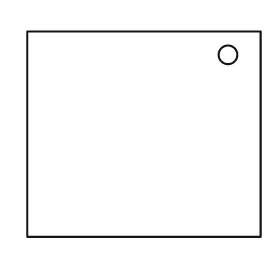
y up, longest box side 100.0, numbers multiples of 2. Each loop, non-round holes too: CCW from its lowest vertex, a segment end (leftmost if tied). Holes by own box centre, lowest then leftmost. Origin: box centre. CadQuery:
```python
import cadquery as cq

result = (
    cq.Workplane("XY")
    .moveTo(-50.0, -44.0)
    .lineTo(50.0, -44.0)
    .lineTo(50.0, 44.0)
    .lineTo(-50.0, 44.0)
    .close()
    .moveTo(36.0, 34.0)
    .circle(4.0)
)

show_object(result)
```